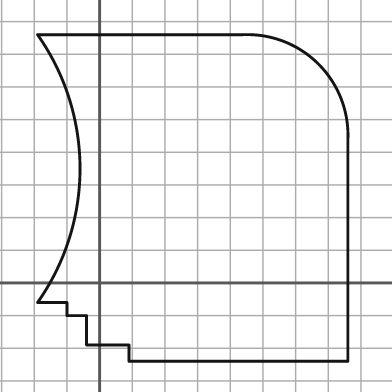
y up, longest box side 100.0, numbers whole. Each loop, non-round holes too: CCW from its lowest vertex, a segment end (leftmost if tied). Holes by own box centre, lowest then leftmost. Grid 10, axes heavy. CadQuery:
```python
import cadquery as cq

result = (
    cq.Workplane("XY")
    .moveTo(9.0, -24.0)
    .lineTo(76.0, -24.0)
    .lineTo(76.0, 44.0)
    .threePointArc((67.0, 67.0), (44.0, 76.0))
    .lineTo(-19.0, 76.0)
    .threePointArc((-6.0, 35.0), (-19.0, -6.0))
    .lineTo(-10.0, -6.0)
    .lineTo(-10.0, -10.0)
    .lineTo(-4.0, -10.0)
    .lineTo(-4.0, -19.0)
    .lineTo(9.0, -19.0)
    .close()
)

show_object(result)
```